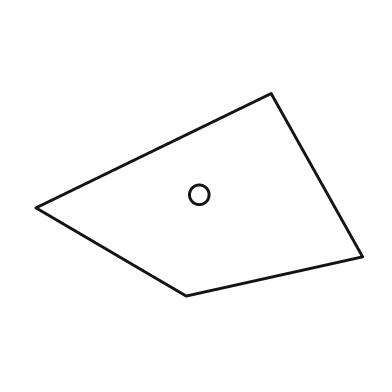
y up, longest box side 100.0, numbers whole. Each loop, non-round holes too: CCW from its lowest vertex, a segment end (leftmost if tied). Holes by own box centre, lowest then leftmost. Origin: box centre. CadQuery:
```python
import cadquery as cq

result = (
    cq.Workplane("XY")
    .moveTo(-4.0, -31.0)
    .lineTo(50.0, -19.0)
    .lineTo(22.0, 31.0)
    .lineTo(-50.0, -4.0)
    .close()
    .moveTo(0.0, 0.0)
    .circle(3.0)
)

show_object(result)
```